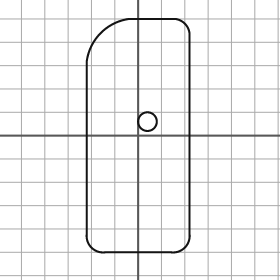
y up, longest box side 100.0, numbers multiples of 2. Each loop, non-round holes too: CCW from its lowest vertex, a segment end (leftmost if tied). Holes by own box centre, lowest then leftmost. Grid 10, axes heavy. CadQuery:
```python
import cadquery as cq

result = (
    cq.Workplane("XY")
    .moveTo(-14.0, -50.0)
    .lineTo(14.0, -50.0)
    .threePointArc((20.0, -48.0), (22.0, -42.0))
    .lineTo(22.0, 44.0)
    .threePointArc((20.0, 48.0), (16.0, 50.0))
    .lineTo(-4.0, 50.0)
    .threePointArc((-16.0, 44.0), (-22.0, 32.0))
    .lineTo(-22.0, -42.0)
    .threePointArc((-20.0, -48.0), (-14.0, -50.0))
    .close()
    .moveTo(4.0, 6.0)
    .circle(4.0)
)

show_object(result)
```